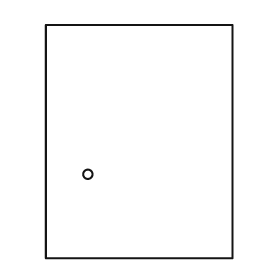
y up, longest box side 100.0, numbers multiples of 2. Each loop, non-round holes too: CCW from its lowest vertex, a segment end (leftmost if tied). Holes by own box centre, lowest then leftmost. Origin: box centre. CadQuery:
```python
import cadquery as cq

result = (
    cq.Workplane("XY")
    .moveTo(-40.0, -50.0)
    .lineTo(40.0, -50.0)
    .lineTo(40.0, 50.0)
    .lineTo(-40.0, 50.0)
    .close()
    .moveTo(-22.0, -14.0)
    .circle(2.0)
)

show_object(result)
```